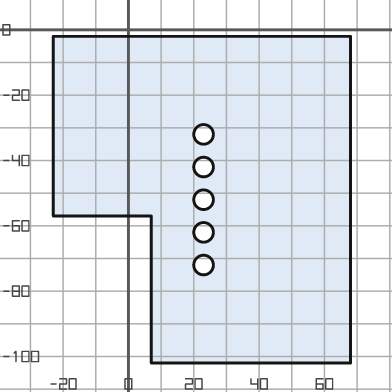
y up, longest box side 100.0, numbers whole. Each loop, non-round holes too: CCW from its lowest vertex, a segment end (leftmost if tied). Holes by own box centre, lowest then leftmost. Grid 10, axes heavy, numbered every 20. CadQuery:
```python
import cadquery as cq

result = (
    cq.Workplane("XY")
    .moveTo(7.0, -102.0)
    .lineTo(68.0, -102.0)
    .lineTo(68.0, -2.0)
    .lineTo(-23.0, -2.0)
    .lineTo(-23.0, -57.0)
    .lineTo(7.0, -57.0)
    .close()
    .moveTo(23.0, -72.0)
    .circle(3.0)
    .moveTo(23.0, -62.0)
    .circle(3.0)
    .moveTo(23.0, -52.0)
    .circle(3.0)
    .moveTo(23.0, -42.0)
    .circle(3.0)
    .moveTo(23.0, -32.0)
    .circle(3.0)
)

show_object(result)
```